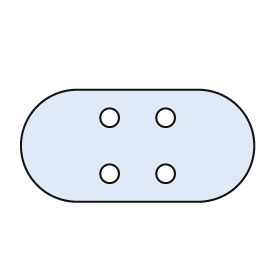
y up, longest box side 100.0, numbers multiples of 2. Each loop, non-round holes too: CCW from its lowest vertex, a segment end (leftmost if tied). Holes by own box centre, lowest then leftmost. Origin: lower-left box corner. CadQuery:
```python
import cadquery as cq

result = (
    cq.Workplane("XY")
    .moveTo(24.0, 0.0)
    .lineTo(76.0, 0.0)
    .threePointArc((100.0, 24.0), (76.0, 48.0))
    .lineTo(24.0, 48.0)
    .threePointArc((0.0, 24.0), (24.0, 0.0))
    .close()
    .moveTo(38.0, 12.0)
    .circle(4.0)
    .moveTo(62.0, 12.0)
    .circle(4.0)
    .moveTo(38.0, 36.0)
    .circle(4.0)
    .moveTo(62.0, 36.0)
    .circle(4.0)
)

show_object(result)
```